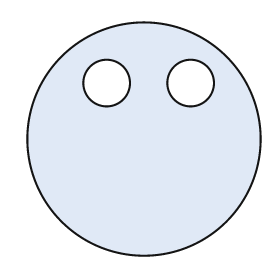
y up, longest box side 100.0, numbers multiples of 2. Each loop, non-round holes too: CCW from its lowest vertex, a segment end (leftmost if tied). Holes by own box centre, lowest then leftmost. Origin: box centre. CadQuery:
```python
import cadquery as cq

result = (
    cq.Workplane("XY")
    .moveTo(0.0, 0.0)
    .circle(50.0)
    .moveTo(-16.0, 24.0)
    .circle(10.0)
    .moveTo(20.0, 24.0)
    .circle(10.0)
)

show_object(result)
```